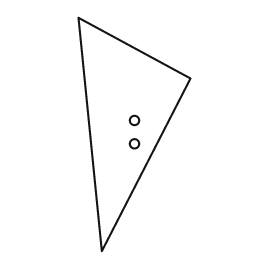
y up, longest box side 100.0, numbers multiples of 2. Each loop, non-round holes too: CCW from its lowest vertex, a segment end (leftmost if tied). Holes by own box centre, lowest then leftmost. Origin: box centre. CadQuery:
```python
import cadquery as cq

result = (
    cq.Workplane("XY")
    .moveTo(-14.0, -50.0)
    .lineTo(24.0, 24.0)
    .lineTo(-24.0, 50.0)
    .close()
    .moveTo(0.0, -4.0)
    .circle(2.0)
    .moveTo(0.0, 6.0)
    .circle(2.0)
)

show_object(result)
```